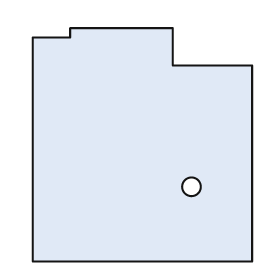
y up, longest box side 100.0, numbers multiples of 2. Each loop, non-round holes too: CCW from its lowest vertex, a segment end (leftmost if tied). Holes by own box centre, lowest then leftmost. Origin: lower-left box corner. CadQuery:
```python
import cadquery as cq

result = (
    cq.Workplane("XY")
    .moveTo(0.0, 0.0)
    .lineTo(94.0, 0.0)
    .lineTo(94.0, 84.0)
    .lineTo(60.0, 84.0)
    .lineTo(60.0, 100.0)
    .lineTo(16.0, 100.0)
    .lineTo(16.0, 96.0)
    .lineTo(0.0, 96.0)
    .close()
    .moveTo(68.0, 32.0)
    .circle(4.0)
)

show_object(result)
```